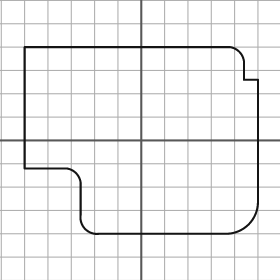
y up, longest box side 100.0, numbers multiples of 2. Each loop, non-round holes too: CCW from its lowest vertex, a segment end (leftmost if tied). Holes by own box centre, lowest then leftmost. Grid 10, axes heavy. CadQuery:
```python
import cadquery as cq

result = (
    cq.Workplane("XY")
    .moveTo(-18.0, -40.0)
    .lineTo(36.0, -40.0)
    .threePointArc((46.0, -36.0), (50.0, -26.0))
    .lineTo(50.0, 26.0)
    .lineTo(44.0, 26.0)
    .lineTo(44.0, 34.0)
    .threePointArc((42.0, 38.0), (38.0, 40.0))
    .lineTo(-50.0, 40.0)
    .lineTo(-50.0, -12.0)
    .lineTo(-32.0, -12.0)
    .threePointArc((-28.0, -14.0), (-26.0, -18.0))
    .lineTo(-26.0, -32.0)
    .threePointArc((-24.0, -38.0), (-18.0, -40.0))
    .close()
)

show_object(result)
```